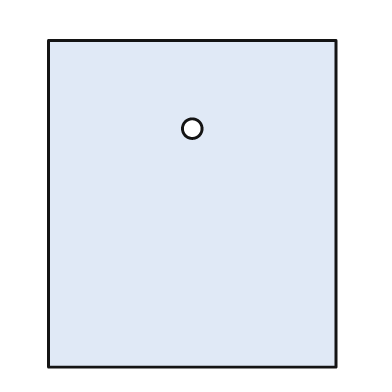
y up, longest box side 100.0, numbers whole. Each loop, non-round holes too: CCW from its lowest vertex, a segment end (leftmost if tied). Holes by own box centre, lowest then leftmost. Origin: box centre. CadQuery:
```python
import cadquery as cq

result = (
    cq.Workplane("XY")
    .moveTo(-44.0, -50.0)
    .lineTo(44.0, -50.0)
    .lineTo(44.0, 50.0)
    .lineTo(-44.0, 50.0)
    .close()
    .moveTo(0.0, 23.0)
    .circle(3.0)
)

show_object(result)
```